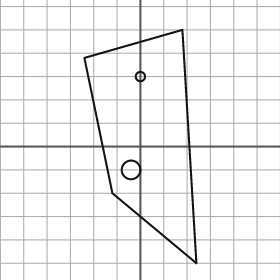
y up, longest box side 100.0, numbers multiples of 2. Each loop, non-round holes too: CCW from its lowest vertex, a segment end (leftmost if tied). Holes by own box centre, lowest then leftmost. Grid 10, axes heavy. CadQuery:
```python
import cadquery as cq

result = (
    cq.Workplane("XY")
    .moveTo(24.0, -50.0)
    .lineTo(18.0, 50.0)
    .lineTo(-24.0, 38.0)
    .lineTo(-12.0, -20.0)
    .close()
    .moveTo(-4.0, -10.0)
    .circle(4.0)
    .moveTo(0.0, 30.0)
    .circle(2.0)
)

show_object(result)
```